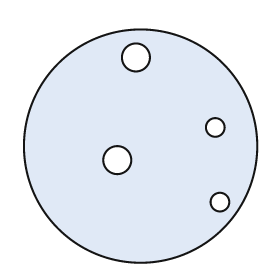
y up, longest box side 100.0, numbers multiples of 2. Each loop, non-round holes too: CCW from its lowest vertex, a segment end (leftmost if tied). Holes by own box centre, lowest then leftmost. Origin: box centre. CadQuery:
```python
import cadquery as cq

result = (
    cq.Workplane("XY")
    .moveTo(0.0, 0.0)
    .circle(50.0)
    .moveTo(34.0, -24.0)
    .circle(4.0)
    .moveTo(-10.0, -6.0)
    .circle(6.0)
    .moveTo(32.0, 8.0)
    .circle(4.0)
    .moveTo(-2.0, 38.0)
    .circle(6.0)
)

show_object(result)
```